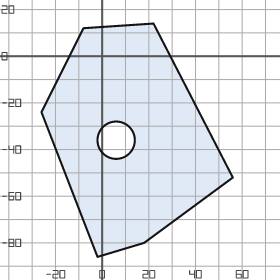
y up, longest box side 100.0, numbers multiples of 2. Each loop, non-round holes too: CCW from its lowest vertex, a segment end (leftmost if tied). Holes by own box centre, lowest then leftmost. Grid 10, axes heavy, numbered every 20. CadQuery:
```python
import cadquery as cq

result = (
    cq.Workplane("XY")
    .moveTo(-2.0, -86.0)
    .lineTo(18.0, -80.0)
    .lineTo(56.0, -52.0)
    .lineTo(22.0, 14.0)
    .lineTo(-8.0, 12.0)
    .lineTo(-26.0, -24.0)
    .close()
    .moveTo(6.0, -36.0)
    .circle(8.0)
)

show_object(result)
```